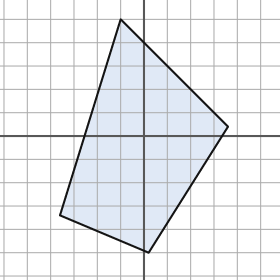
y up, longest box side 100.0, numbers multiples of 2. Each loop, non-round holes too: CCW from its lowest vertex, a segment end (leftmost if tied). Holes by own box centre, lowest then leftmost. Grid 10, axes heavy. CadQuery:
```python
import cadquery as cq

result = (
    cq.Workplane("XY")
    .moveTo(2.0, -50.0)
    .lineTo(36.0, 4.0)
    .lineTo(-10.0, 50.0)
    .lineTo(-36.0, -34.0)
    .close()
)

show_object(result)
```